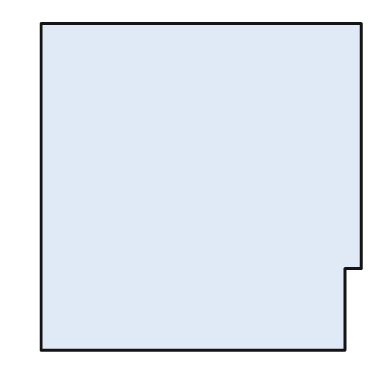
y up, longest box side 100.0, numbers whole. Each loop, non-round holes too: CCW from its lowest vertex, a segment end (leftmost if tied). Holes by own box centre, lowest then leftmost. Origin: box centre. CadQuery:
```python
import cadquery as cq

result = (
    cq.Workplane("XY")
    .moveTo(-49.0, -50.0)
    .lineTo(44.0, -50.0)
    .lineTo(44.0, -25.0)
    .lineTo(49.0, -25.0)
    .lineTo(49.0, 50.0)
    .lineTo(-49.0, 50.0)
    .close()
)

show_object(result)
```